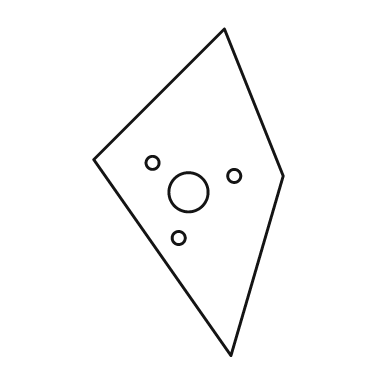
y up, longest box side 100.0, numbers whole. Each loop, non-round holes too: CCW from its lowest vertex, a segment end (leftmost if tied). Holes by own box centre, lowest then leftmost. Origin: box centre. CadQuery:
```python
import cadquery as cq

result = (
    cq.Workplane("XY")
    .moveTo(13.0, -50.0)
    .lineTo(29.0, 5.0)
    .lineTo(11.0, 50.0)
    .lineTo(-29.0, 10.0)
    .close()
    .moveTo(-3.0, -14.0)
    .circle(2.0)
    .moveTo(0.0, 0.0)
    .circle(6.0)
    .moveTo(14.0, 5.0)
    .circle(2.0)
    .moveTo(-11.0, 9.0)
    .circle(2.0)
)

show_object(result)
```